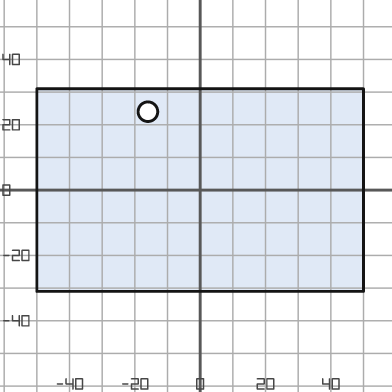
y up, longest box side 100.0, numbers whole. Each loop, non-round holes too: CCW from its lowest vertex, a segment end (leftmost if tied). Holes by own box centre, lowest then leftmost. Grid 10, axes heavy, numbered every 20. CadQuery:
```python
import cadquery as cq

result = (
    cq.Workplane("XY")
    .moveTo(-50.0, -31.0)
    .lineTo(50.0, -31.0)
    .lineTo(50.0, 31.0)
    .lineTo(-50.0, 31.0)
    .close()
    .moveTo(-16.0, 24.0)
    .circle(3.0)
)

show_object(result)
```